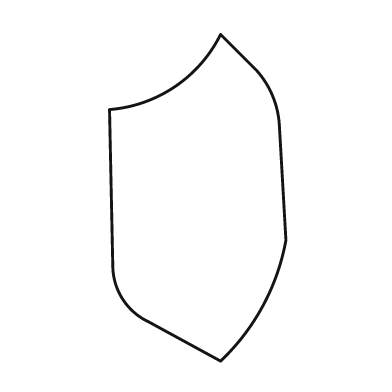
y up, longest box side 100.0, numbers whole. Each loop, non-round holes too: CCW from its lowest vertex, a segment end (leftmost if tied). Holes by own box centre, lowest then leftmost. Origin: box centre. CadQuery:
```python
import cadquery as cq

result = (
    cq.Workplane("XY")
    .moveTo(7.0, -50.0)
    .threePointArc((20.0, -33.0), (27.0, -13.0))
    .lineTo(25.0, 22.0)
    .threePointArc((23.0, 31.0), (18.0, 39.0))
    .lineTo(7.0, 50.0)
    .threePointArc((-7.0, 34.0), (-27.0, 27.0))
    .lineTo(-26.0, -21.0)
    .threePointArc((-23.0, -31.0), (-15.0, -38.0))
    .close()
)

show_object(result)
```